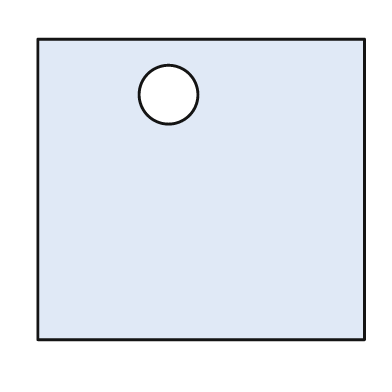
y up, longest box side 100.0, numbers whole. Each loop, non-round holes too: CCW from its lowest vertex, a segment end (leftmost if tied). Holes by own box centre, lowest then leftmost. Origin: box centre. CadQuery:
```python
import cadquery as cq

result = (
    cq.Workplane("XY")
    .moveTo(-50.0, -46.0)
    .lineTo(50.0, -46.0)
    .lineTo(50.0, 46.0)
    .lineTo(-50.0, 46.0)
    .close()
    .moveTo(-10.0, 29.0)
    .circle(9.0)
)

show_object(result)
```